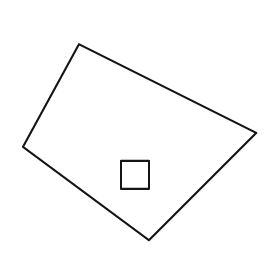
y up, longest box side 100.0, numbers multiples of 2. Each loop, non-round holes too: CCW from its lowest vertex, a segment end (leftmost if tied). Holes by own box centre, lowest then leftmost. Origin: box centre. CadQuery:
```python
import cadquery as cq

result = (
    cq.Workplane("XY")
    .moveTo(4.0, -42.0)
    .lineTo(50.0, 4.0)
    .lineTo(-26.0, 42.0)
    .lineTo(-50.0, -2.0)
    .close()
    .moveTo(-8.0, -20.0)
    .lineTo(4.0, -20.0)
    .lineTo(4.0, -8.0)
    .lineTo(-8.0, -8.0)
    .close()
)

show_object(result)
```